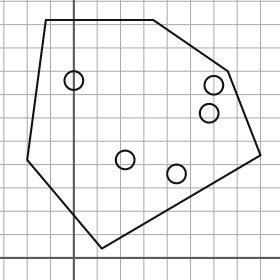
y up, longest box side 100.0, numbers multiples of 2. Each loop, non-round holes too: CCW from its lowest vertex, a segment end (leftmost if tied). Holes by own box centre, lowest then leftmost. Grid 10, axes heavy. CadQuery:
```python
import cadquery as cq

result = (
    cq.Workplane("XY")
    .moveTo(12.0, 4.0)
    .lineTo(80.0, 44.0)
    .lineTo(66.0, 80.0)
    .lineTo(34.0, 102.0)
    .lineTo(-12.0, 102.0)
    .lineTo(-20.0, 42.0)
    .close()
    .moveTo(44.0, 36.0)
    .circle(4.0)
    .moveTo(22.0, 42.0)
    .circle(4.0)
    .moveTo(58.0, 62.0)
    .circle(4.0)
    .moveTo(60.0, 74.0)
    .circle(4.0)
    .moveTo(0.0, 76.0)
    .circle(4.0)
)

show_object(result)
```